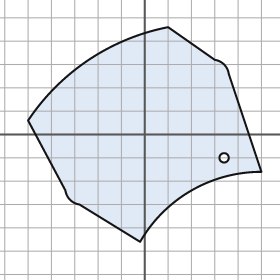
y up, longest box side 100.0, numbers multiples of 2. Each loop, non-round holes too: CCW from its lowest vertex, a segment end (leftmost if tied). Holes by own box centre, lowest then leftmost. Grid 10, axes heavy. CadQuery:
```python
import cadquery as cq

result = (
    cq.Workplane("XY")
    .moveTo(-2.0, -46.0)
    .threePointArc((20.0, -24.0), (50.0, -16.0))
    .lineTo(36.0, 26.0)
    .threePointArc((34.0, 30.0), (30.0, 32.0))
    .lineTo(10.0, 46.0)
    .threePointArc((-24.0, 32.0), (-50.0, 6.0))
    .lineTo(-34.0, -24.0)
    .threePointArc((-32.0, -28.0), (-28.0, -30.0))
    .close()
    .moveTo(34.0, -10.0)
    .circle(2.0)
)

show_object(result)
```